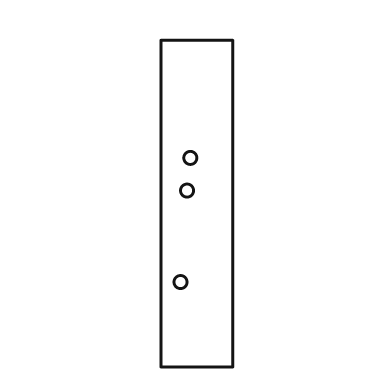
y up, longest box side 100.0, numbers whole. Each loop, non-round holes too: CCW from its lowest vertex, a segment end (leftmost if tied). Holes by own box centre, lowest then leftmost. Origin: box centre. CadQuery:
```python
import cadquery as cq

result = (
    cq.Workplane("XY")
    .moveTo(-11.0, -50.0)
    .lineTo(11.0, -50.0)
    .lineTo(11.0, 50.0)
    .lineTo(-11.0, 50.0)
    .close()
    .moveTo(-5.0, -24.0)
    .circle(2.0)
    .moveTo(-3.0, 4.0)
    .circle(2.0)
    .moveTo(-2.0, 14.0)
    .circle(2.0)
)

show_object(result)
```